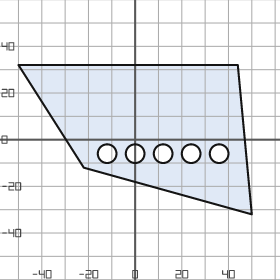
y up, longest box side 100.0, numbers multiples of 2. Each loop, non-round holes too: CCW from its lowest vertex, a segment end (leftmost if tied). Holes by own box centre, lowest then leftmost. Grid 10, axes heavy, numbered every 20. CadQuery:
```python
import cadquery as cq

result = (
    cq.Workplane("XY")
    .moveTo(50.0, -32.0)
    .lineTo(44.0, 32.0)
    .lineTo(-50.0, 32.0)
    .lineTo(-22.0, -12.0)
    .close()
    .moveTo(-12.0, -6.0)
    .circle(4.0)
    .moveTo(0.0, -6.0)
    .circle(4.0)
    .moveTo(12.0, -6.0)
    .circle(4.0)
    .moveTo(24.0, -6.0)
    .circle(4.0)
    .moveTo(36.0, -6.0)
    .circle(4.0)
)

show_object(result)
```